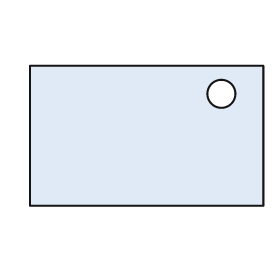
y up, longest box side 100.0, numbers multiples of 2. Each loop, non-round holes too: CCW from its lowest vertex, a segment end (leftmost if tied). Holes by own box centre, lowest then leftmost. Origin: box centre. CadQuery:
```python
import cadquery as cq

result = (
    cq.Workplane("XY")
    .moveTo(-50.0, -30.0)
    .lineTo(50.0, -30.0)
    .lineTo(50.0, 30.0)
    .lineTo(-50.0, 30.0)
    .close()
    .moveTo(32.0, 18.0)
    .circle(6.0)
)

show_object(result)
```